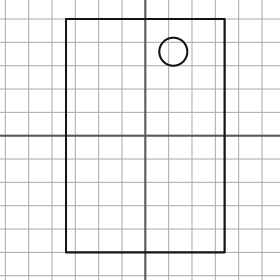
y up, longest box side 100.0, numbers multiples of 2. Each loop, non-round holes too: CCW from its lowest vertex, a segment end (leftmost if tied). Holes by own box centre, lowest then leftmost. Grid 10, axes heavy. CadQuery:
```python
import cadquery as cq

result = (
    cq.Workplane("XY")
    .moveTo(-34.0, -50.0)
    .lineTo(34.0, -50.0)
    .lineTo(34.0, 50.0)
    .lineTo(-34.0, 50.0)
    .close()
    .moveTo(12.0, 36.0)
    .circle(6.0)
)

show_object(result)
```